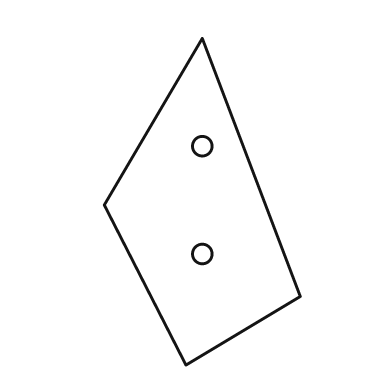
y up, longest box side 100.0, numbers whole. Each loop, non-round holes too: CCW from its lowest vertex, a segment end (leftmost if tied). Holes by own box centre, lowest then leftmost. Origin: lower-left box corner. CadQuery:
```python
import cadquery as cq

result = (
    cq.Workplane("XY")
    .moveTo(25.0, 0.0)
    .lineTo(60.0, 21.0)
    .lineTo(30.0, 100.0)
    .lineTo(0.0, 49.0)
    .close()
    .moveTo(30.0, 34.0)
    .circle(3.0)
    .moveTo(30.0, 67.0)
    .circle(3.0)
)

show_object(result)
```